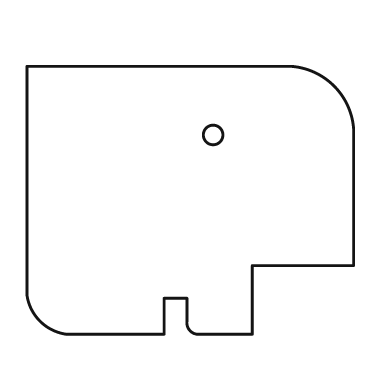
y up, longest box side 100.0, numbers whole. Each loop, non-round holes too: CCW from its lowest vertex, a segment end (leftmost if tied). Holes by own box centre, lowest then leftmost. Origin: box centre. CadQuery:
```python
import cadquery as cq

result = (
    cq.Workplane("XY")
    .moveTo(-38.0, -41.0)
    .lineTo(-8.0, -41.0)
    .lineTo(-8.0, -30.0)
    .lineTo(-1.0, -30.0)
    .lineTo(-1.0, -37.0)
    .threePointArc((0.0, -40.0), (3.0, -41.0))
    .lineTo(19.0, -41.0)
    .lineTo(19.0, -20.0)
    .lineTo(50.0, -20.0)
    .lineTo(50.0, 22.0)
    .threePointArc((44.0, 35.0), (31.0, 41.0))
    .lineTo(-50.0, 41.0)
    .lineTo(-50.0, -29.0)
    .threePointArc((-46.0, -37.0), (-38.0, -41.0))
    .close()
    .moveTo(7.0, 20.0)
    .circle(3.0)
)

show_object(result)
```